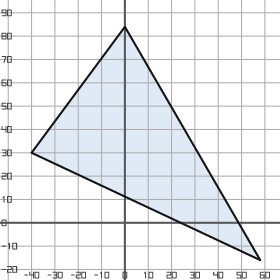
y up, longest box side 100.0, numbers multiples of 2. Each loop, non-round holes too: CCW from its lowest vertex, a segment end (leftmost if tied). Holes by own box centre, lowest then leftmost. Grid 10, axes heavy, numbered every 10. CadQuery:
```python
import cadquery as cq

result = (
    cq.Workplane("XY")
    .moveTo(58.0, -16.0)
    .lineTo(0.0, 84.0)
    .lineTo(-40.0, 30.0)
    .close()
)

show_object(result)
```